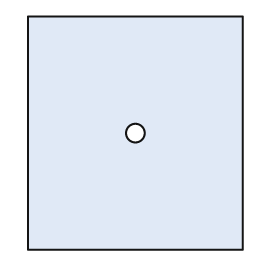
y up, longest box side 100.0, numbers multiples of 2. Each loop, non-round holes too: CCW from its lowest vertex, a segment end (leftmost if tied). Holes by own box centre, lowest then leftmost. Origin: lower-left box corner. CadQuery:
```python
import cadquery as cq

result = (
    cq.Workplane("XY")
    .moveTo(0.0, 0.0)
    .lineTo(92.0, 0.0)
    .lineTo(92.0, 100.0)
    .lineTo(0.0, 100.0)
    .close()
    .moveTo(46.0, 50.0)
    .circle(4.0)
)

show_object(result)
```